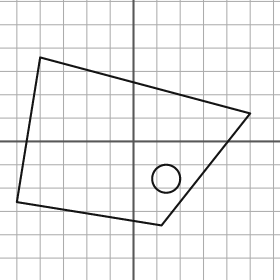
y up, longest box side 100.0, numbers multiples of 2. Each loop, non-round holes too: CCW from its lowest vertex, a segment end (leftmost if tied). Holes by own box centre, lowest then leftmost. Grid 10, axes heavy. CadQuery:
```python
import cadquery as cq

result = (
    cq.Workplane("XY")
    .moveTo(12.0, -36.0)
    .lineTo(50.0, 12.0)
    .lineTo(-40.0, 36.0)
    .lineTo(-50.0, -26.0)
    .close()
    .moveTo(14.0, -16.0)
    .circle(6.0)
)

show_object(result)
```